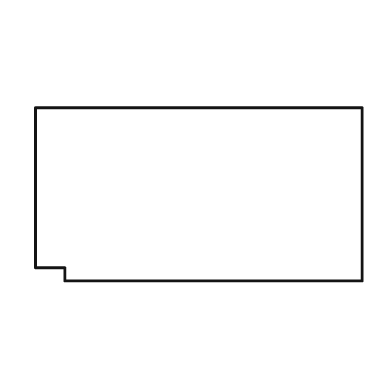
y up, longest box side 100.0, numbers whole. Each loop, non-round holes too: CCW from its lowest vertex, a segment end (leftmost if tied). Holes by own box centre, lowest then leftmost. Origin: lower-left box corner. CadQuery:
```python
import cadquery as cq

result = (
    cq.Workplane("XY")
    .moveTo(9.0, 0.0)
    .lineTo(100.0, 0.0)
    .lineTo(100.0, 53.0)
    .lineTo(0.0, 53.0)
    .lineTo(0.0, 4.0)
    .lineTo(9.0, 4.0)
    .close()
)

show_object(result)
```